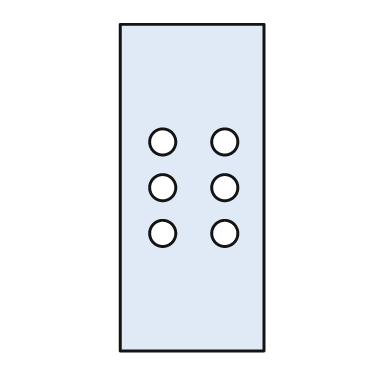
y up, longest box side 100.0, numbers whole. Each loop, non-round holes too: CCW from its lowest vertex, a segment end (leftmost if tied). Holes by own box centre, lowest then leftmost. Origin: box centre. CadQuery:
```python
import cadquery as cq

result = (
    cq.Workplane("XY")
    .moveTo(-22.0, -50.0)
    .lineTo(22.0, -50.0)
    .lineTo(22.0, 50.0)
    .lineTo(-22.0, 50.0)
    .close()
    .moveTo(-9.0, -14.0)
    .circle(4.0)
    .moveTo(10.0, -14.0)
    .circle(4.0)
    .moveTo(-9.0, 0.0)
    .circle(4.0)
    .moveTo(10.0, 0.0)
    .circle(4.0)
    .moveTo(-9.0, 14.0)
    .circle(4.0)
    .moveTo(10.0, 14.0)
    .circle(4.0)
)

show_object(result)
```